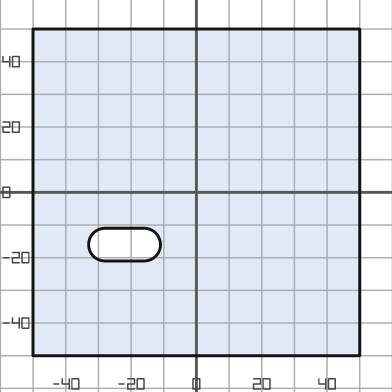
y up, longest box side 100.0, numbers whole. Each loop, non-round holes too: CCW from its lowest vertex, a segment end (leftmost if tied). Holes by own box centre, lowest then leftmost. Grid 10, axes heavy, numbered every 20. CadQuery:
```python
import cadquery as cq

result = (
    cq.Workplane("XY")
    .moveTo(-50.0, -50.0)
    .lineTo(50.0, -50.0)
    .lineTo(50.0, 50.0)
    .lineTo(-50.0, 50.0)
    .close()
    .moveTo(-28.0, -21.0)
    .lineTo(-16.0, -21.0)
    .threePointArc((-11.0, -16.0), (-16.0, -11.0))
    .lineTo(-28.0, -11.0)
    .threePointArc((-33.0, -16.0), (-28.0, -21.0))
    .close()
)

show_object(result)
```